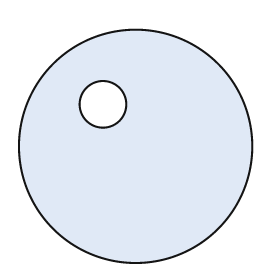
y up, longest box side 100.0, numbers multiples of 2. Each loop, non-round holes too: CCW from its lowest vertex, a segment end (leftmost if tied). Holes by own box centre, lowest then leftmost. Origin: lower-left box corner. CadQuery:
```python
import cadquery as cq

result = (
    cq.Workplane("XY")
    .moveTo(50.0, 50.0)
    .circle(50.0)
    .moveTo(36.0, 68.0)
    .circle(10.0)
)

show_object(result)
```